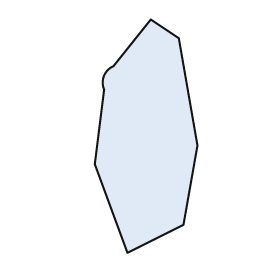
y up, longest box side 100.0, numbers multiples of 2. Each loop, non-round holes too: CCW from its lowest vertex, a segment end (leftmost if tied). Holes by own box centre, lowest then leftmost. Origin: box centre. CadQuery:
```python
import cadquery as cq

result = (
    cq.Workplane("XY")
    .moveTo(-8.0, -50.0)
    .lineTo(16.0, -38.0)
    .lineTo(22.0, -4.0)
    .lineTo(14.0, 42.0)
    .lineTo(2.0, 50.0)
    .lineTo(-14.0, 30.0)
    .threePointArc((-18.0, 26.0), (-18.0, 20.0))
    .lineTo(-22.0, -12.0)
    .close()
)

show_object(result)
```